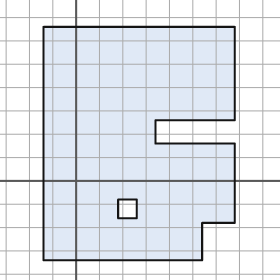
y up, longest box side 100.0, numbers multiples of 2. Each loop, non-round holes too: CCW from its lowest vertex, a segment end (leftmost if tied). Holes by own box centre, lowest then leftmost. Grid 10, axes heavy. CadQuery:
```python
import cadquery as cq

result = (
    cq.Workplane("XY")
    .moveTo(-14.0, -34.0)
    .lineTo(54.0, -34.0)
    .lineTo(54.0, -18.0)
    .lineTo(68.0, -18.0)
    .lineTo(68.0, 16.0)
    .lineTo(34.0, 16.0)
    .lineTo(34.0, 26.0)
    .lineTo(68.0, 26.0)
    .lineTo(68.0, 66.0)
    .lineTo(-14.0, 66.0)
    .close()
    .moveTo(18.0, -16.0)
    .lineTo(26.0, -16.0)
    .lineTo(26.0, -8.0)
    .lineTo(18.0, -8.0)
    .close()
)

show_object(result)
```